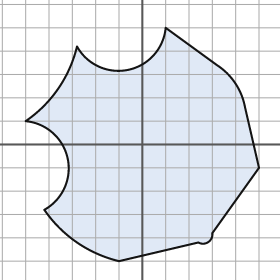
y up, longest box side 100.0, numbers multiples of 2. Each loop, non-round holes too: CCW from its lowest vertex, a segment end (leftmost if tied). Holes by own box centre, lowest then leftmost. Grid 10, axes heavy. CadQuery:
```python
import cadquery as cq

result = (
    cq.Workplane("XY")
    .moveTo(-10.0, -50.0)
    .lineTo(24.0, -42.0)
    .threePointArc((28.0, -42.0), (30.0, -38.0))
    .lineTo(50.0, -10.0)
    .lineTo(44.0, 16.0)
    .threePointArc((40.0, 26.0), (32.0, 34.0))
    .lineTo(10.0, 50.0)
    .threePointArc((-6.0, 32.0), (-28.0, 42.0))
    .threePointArc((-36.0, 24.0), (-50.0, 10.0))
    .threePointArc((-32.0, -6.0), (-42.0, -28.0))
    .threePointArc((-28.0, -42.0), (-10.0, -50.0))
    .close()
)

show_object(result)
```